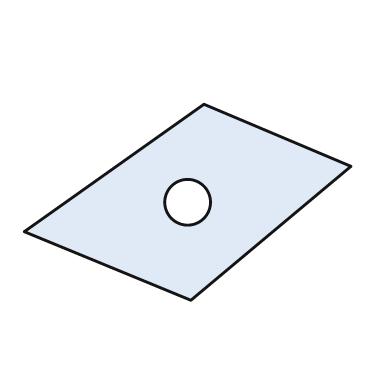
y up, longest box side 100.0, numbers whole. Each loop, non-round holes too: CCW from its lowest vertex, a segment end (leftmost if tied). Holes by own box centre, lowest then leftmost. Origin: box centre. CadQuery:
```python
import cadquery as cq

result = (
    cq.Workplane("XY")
    .moveTo(1.0, -30.0)
    .lineTo(50.0, 11.0)
    .lineTo(5.0, 30.0)
    .lineTo(-50.0, -9.0)
    .close()
    .moveTo(0.0, 0.0)
    .circle(7.0)
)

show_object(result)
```